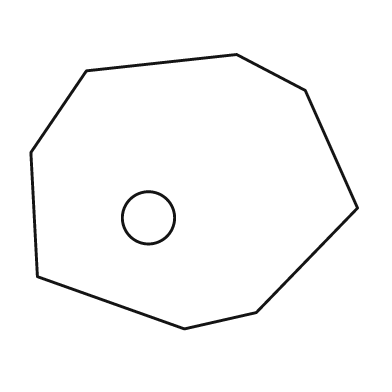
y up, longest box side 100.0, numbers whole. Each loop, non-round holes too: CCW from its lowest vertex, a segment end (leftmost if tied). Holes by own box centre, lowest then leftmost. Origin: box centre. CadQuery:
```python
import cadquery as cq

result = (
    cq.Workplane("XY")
    .moveTo(-3.0, -42.0)
    .lineTo(19.0, -37.0)
    .lineTo(50.0, -5.0)
    .lineTo(34.0, 31.0)
    .lineTo(13.0, 42.0)
    .lineTo(-33.0, 37.0)
    .lineTo(-50.0, 12.0)
    .lineTo(-48.0, -26.0)
    .close()
    .moveTo(-14.0, -8.0)
    .circle(8.0)
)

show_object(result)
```